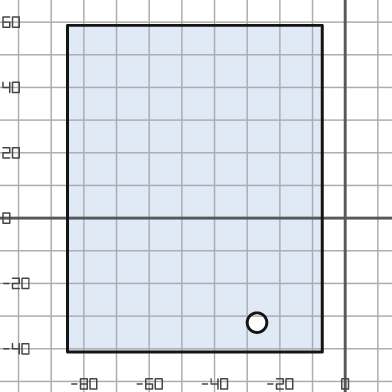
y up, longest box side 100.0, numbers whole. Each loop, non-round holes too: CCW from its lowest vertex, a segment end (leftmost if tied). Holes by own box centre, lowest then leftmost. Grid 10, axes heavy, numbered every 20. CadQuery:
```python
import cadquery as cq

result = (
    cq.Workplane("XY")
    .moveTo(-85.0, -41.0)
    .lineTo(-7.0, -41.0)
    .lineTo(-7.0, 59.0)
    .lineTo(-85.0, 59.0)
    .close()
    .moveTo(-27.0, -32.0)
    .circle(3.0)
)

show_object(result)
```